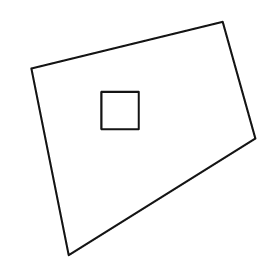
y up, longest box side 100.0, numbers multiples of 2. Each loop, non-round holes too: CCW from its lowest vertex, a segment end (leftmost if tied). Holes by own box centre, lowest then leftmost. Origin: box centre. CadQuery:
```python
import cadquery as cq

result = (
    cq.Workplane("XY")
    .moveTo(-32.0, -50.0)
    .lineTo(48.0, 0.0)
    .lineTo(34.0, 50.0)
    .lineTo(-48.0, 30.0)
    .close()
    .moveTo(-18.0, 4.0)
    .lineTo(-2.0, 4.0)
    .lineTo(-2.0, 20.0)
    .lineTo(-18.0, 20.0)
    .close()
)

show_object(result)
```